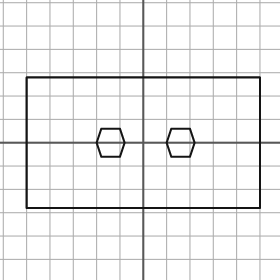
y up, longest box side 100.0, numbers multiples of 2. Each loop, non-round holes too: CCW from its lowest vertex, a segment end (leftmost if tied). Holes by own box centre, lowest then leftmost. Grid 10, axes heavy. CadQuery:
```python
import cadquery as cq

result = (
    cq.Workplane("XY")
    .moveTo(-50.0, -28.0)
    .lineTo(50.0, -28.0)
    .lineTo(50.0, 28.0)
    .lineTo(-50.0, 28.0)
    .close()
    .moveTo(-18.0, -6.0)
    .lineTo(-10.0, -6.0)
    .lineTo(-8.0, 0.0)
    .lineTo(-10.0, 6.0)
    .lineTo(-18.0, 6.0)
    .lineTo(-20.0, 0.0)
    .close()
    .moveTo(12.0, -6.0)
    .lineTo(20.0, -6.0)
    .lineTo(22.0, 0.0)
    .lineTo(20.0, 6.0)
    .lineTo(12.0, 6.0)
    .lineTo(10.0, 0.0)
    .close()
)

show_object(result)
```